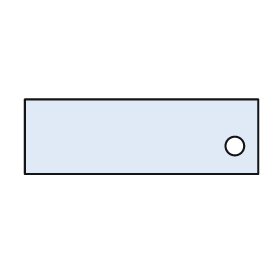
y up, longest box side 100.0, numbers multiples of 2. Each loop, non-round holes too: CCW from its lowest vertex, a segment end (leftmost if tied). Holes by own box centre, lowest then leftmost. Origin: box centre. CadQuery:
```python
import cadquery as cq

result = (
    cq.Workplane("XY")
    .moveTo(-50.0, -16.0)
    .lineTo(50.0, -16.0)
    .lineTo(50.0, 16.0)
    .lineTo(-50.0, 16.0)
    .close()
    .moveTo(40.0, -4.0)
    .circle(4.0)
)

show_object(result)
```